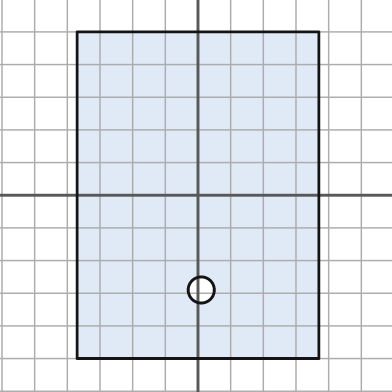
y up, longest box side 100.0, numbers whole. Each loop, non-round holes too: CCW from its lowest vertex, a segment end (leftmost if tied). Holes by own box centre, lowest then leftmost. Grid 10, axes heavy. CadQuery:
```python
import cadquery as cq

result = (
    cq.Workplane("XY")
    .moveTo(-37.0, -50.0)
    .lineTo(37.0, -50.0)
    .lineTo(37.0, 50.0)
    .lineTo(-37.0, 50.0)
    .close()
    .moveTo(1.0, -29.0)
    .circle(4.0)
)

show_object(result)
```